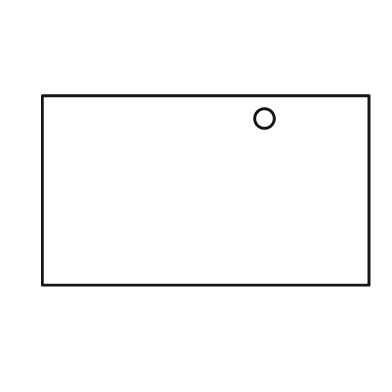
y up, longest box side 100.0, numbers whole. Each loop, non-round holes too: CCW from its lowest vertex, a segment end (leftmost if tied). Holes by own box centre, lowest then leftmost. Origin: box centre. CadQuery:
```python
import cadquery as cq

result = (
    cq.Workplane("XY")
    .moveTo(-50.0, -29.0)
    .lineTo(50.0, -29.0)
    .lineTo(50.0, 29.0)
    .lineTo(-50.0, 29.0)
    .close()
    .moveTo(18.0, 22.0)
    .circle(3.0)
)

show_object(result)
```